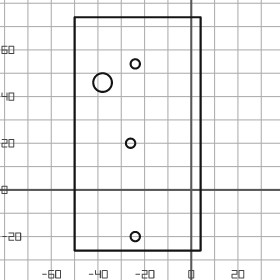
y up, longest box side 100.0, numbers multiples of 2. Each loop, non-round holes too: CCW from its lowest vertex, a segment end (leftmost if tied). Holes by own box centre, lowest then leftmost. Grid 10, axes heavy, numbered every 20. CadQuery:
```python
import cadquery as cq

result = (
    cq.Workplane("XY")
    .moveTo(-50.0, -26.0)
    .lineTo(4.0, -26.0)
    .lineTo(4.0, 74.0)
    .lineTo(-50.0, 74.0)
    .close()
    .moveTo(-24.0, -20.0)
    .circle(2.0)
    .moveTo(-26.0, 20.0)
    .circle(2.0)
    .moveTo(-38.0, 46.0)
    .circle(4.0)
    .moveTo(-24.0, 54.0)
    .circle(2.0)
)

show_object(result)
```